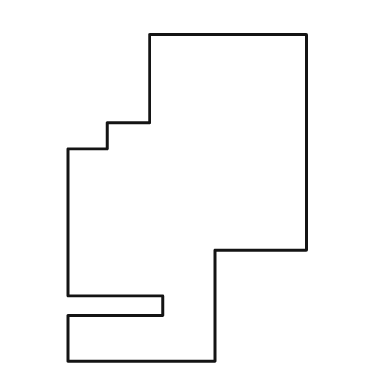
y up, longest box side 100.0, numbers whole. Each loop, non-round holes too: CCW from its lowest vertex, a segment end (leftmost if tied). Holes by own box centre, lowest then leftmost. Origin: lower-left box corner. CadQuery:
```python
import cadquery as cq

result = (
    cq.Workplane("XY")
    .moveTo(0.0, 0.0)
    .lineTo(45.0, 0.0)
    .lineTo(45.0, 34.0)
    .lineTo(73.0, 34.0)
    .lineTo(73.0, 100.0)
    .lineTo(25.0, 100.0)
    .lineTo(25.0, 73.0)
    .lineTo(12.0, 73.0)
    .lineTo(12.0, 65.0)
    .lineTo(0.0, 65.0)
    .lineTo(0.0, 20.0)
    .lineTo(29.0, 20.0)
    .lineTo(29.0, 14.0)
    .lineTo(0.0, 14.0)
    .close()
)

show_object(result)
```